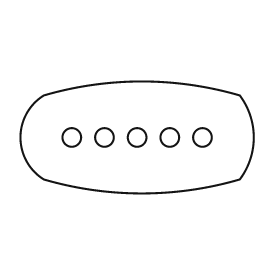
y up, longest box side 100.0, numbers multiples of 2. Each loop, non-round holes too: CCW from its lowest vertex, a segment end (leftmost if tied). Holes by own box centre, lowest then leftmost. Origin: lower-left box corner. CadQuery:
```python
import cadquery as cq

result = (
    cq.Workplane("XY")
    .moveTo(10.0, 6.0)
    .threePointArc((52.0, 0.0), (94.0, 6.0))
    .threePointArc((100.0, 24.0), (94.0, 42.0))
    .threePointArc((52.0, 48.0), (10.0, 42.0))
    .threePointArc((0.0, 24.0), (10.0, 6.0))
    .close()
    .moveTo(22.0, 24.0)
    .circle(4.0)
    .moveTo(36.0, 24.0)
    .circle(4.0)
    .moveTo(50.0, 24.0)
    .circle(4.0)
    .moveTo(64.0, 24.0)
    .circle(4.0)
    .moveTo(78.0, 24.0)
    .circle(4.0)
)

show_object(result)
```